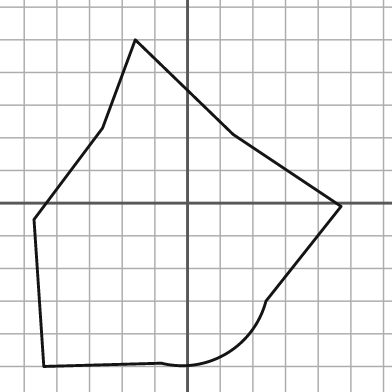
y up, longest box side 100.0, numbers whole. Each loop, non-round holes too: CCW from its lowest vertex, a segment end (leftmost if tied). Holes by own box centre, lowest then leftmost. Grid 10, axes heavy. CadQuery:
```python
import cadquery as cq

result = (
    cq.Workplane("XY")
    .moveTo(-44.0, -50.0)
    .lineTo(-8.0, -49.0)
    .threePointArc((12.0, -46.0), (24.0, -30.0))
    .lineTo(47.0, -1.0)
    .lineTo(14.0, 21.0)
    .lineTo(-16.0, 50.0)
    .lineTo(-26.0, 23.0)
    .lineTo(-47.0, -5.0)
    .close()
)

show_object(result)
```